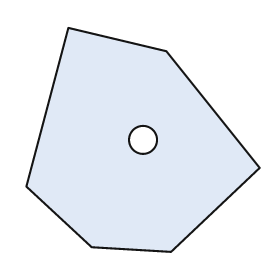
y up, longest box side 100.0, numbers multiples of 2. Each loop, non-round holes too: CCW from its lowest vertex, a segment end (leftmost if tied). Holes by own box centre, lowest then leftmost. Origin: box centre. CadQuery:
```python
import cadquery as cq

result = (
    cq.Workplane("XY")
    .moveTo(12.0, -48.0)
    .lineTo(50.0, -12.0)
    .lineTo(10.0, 38.0)
    .lineTo(-32.0, 48.0)
    .lineTo(-50.0, -20.0)
    .lineTo(-22.0, -46.0)
    .close()
    .moveTo(0.0, 0.0)
    .circle(6.0)
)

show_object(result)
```